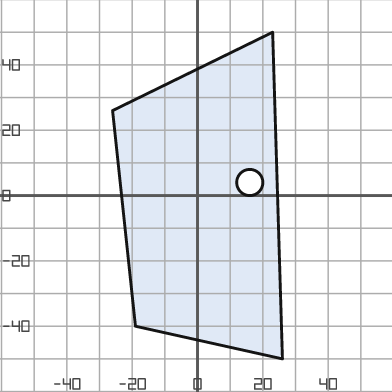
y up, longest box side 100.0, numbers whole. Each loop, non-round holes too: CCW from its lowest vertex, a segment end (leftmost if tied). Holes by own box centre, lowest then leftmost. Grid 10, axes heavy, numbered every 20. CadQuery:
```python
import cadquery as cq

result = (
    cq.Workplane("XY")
    .moveTo(26.0, -50.0)
    .lineTo(23.0, 50.0)
    .lineTo(-26.0, 26.0)
    .lineTo(-19.0, -40.0)
    .close()
    .moveTo(16.0, 4.0)
    .circle(4.0)
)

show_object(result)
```